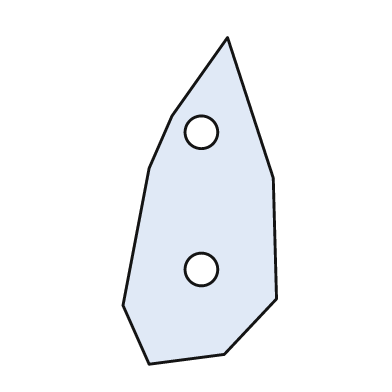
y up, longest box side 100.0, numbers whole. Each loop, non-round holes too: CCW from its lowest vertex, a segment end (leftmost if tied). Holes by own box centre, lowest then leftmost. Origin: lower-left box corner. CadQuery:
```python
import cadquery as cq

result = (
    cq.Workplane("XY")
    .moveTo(8.0, 0.0)
    .lineTo(31.0, 3.0)
    .lineTo(47.0, 20.0)
    .lineTo(46.0, 57.0)
    .lineTo(32.0, 100.0)
    .lineTo(15.0, 76.0)
    .lineTo(8.0, 60.0)
    .lineTo(0.0, 18.0)
    .close()
    .moveTo(24.0, 29.0)
    .circle(5.0)
    .moveTo(24.0, 71.0)
    .circle(5.0)
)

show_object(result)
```